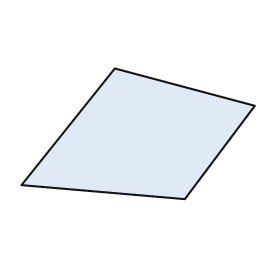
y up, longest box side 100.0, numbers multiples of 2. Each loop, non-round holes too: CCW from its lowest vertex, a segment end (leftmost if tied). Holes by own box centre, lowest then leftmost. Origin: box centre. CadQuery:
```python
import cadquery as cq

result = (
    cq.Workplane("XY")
    .moveTo(20.0, -28.0)
    .lineTo(50.0, 12.0)
    .lineTo(-10.0, 28.0)
    .lineTo(-50.0, -22.0)
    .close()
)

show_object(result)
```